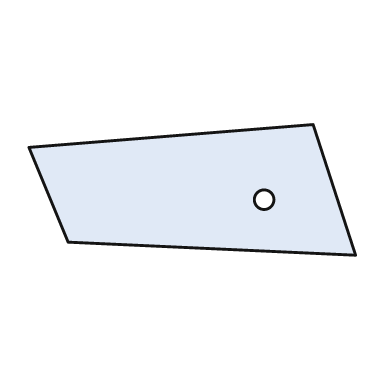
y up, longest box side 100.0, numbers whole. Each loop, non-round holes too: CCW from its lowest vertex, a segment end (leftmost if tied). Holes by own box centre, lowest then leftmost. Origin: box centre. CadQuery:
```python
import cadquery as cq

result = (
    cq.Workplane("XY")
    .moveTo(50.0, -20.0)
    .lineTo(37.0, 20.0)
    .lineTo(-50.0, 13.0)
    .lineTo(-38.0, -16.0)
    .close()
    .moveTo(22.0, -3.0)
    .circle(3.0)
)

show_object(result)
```